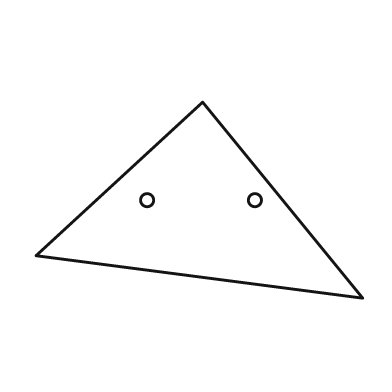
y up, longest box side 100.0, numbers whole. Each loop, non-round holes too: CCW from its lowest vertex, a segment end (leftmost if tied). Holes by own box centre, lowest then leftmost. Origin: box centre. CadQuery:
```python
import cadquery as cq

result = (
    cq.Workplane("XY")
    .moveTo(50.0, -30.0)
    .lineTo(1.0, 30.0)
    .lineTo(-50.0, -17.0)
    .close()
    .moveTo(-16.0, 0.0)
    .circle(2.0)
    .moveTo(17.0, 0.0)
    .circle(2.0)
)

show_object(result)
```